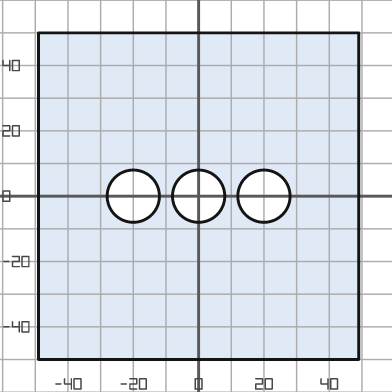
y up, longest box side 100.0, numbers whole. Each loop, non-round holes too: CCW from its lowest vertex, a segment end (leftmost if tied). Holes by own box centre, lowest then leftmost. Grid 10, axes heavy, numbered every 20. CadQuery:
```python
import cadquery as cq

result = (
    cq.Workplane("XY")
    .moveTo(-49.0, -50.0)
    .lineTo(49.0, -50.0)
    .lineTo(49.0, 50.0)
    .lineTo(-49.0, 50.0)
    .close()
    .moveTo(-20.0, 0.0)
    .circle(8.0)
    .moveTo(0.0, 0.0)
    .circle(8.0)
    .moveTo(20.0, 0.0)
    .circle(8.0)
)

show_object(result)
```